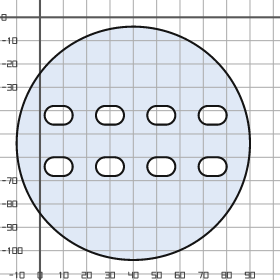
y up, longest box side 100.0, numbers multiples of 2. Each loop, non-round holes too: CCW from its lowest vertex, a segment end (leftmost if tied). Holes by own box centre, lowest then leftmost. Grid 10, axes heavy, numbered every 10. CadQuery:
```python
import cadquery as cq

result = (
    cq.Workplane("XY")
    .moveTo(40.0, -54.0)
    .circle(50.0)
    .moveTo(6.0, -68.0)
    .lineTo(10.0, -68.0)
    .threePointArc((14.0, -64.0), (10.0, -60.0))
    .lineTo(6.0, -60.0)
    .threePointArc((2.0, -64.0), (6.0, -68.0))
    .close()
    .moveTo(28.0, -68.0)
    .lineTo(32.0, -68.0)
    .threePointArc((36.0, -64.0), (32.0, -60.0))
    .lineTo(28.0, -60.0)
    .threePointArc((24.0, -64.0), (28.0, -68.0))
    .close()
    .moveTo(50.0, -68.0)
    .lineTo(54.0, -68.0)
    .threePointArc((58.0, -64.0), (54.0, -60.0))
    .lineTo(50.0, -60.0)
    .threePointArc((46.0, -64.0), (50.0, -68.0))
    .close()
    .moveTo(72.0, -68.0)
    .lineTo(76.0, -68.0)
    .threePointArc((80.0, -64.0), (76.0, -60.0))
    .lineTo(72.0, -60.0)
    .threePointArc((68.0, -64.0), (72.0, -68.0))
    .close()
    .moveTo(6.0, -46.0)
    .lineTo(10.0, -46.0)
    .threePointArc((14.0, -42.0), (10.0, -38.0))
    .lineTo(6.0, -38.0)
    .threePointArc((2.0, -42.0), (6.0, -46.0))
    .close()
    .moveTo(28.0, -46.0)
    .lineTo(32.0, -46.0)
    .threePointArc((36.0, -42.0), (32.0, -38.0))
    .lineTo(28.0, -38.0)
    .threePointArc((24.0, -42.0), (28.0, -46.0))
    .close()
    .moveTo(50.0, -46.0)
    .lineTo(54.0, -46.0)
    .threePointArc((58.0, -42.0), (54.0, -38.0))
    .lineTo(50.0, -38.0)
    .threePointArc((46.0, -42.0), (50.0, -46.0))
    .close()
    .moveTo(72.0, -46.0)
    .lineTo(76.0, -46.0)
    .threePointArc((80.0, -42.0), (76.0, -38.0))
    .lineTo(72.0, -38.0)
    .threePointArc((68.0, -42.0), (72.0, -46.0))
    .close()
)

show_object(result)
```